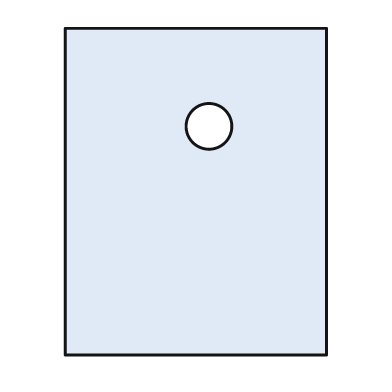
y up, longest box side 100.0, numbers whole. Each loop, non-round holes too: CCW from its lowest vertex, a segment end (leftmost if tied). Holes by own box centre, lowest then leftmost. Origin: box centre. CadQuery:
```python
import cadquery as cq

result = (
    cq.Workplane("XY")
    .moveTo(-40.0, -50.0)
    .lineTo(40.0, -50.0)
    .lineTo(40.0, 50.0)
    .lineTo(-40.0, 50.0)
    .close()
    .moveTo(4.0, 20.0)
    .circle(7.0)
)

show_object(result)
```